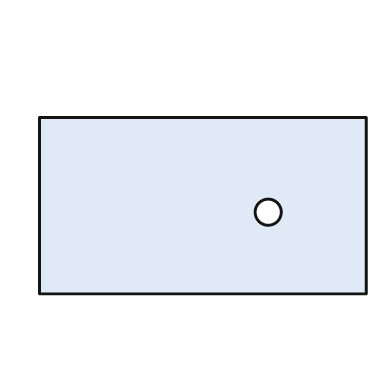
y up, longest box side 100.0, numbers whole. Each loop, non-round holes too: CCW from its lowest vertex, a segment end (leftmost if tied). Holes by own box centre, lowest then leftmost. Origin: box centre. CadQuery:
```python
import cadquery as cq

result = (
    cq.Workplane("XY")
    .moveTo(-50.0, -27.0)
    .lineTo(50.0, -27.0)
    .lineTo(50.0, 27.0)
    .lineTo(-50.0, 27.0)
    .close()
    .moveTo(20.0, -2.0)
    .circle(4.0)
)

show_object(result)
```